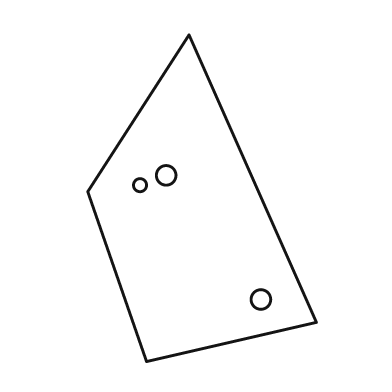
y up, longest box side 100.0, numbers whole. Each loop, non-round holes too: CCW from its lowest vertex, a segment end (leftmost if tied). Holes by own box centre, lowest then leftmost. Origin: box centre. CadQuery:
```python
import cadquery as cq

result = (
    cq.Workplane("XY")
    .moveTo(-17.0, -50.0)
    .lineTo(35.0, -38.0)
    .lineTo(-4.0, 50.0)
    .lineTo(-35.0, 2.0)
    .close()
    .moveTo(18.0, -31.0)
    .circle(3.0)
    .moveTo(-19.0, 4.0)
    .circle(2.0)
    .moveTo(-11.0, 7.0)
    .circle(3.0)
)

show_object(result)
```